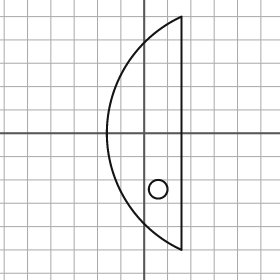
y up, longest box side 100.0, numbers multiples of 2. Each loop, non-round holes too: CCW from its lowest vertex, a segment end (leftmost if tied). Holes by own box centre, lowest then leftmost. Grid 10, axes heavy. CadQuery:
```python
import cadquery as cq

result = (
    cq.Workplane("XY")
    .moveTo(16.0, -50.0)
    .lineTo(16.0, 50.0)
    .threePointArc((-16.0, 0.0), (16.0, -50.0))
    .close()
    .moveTo(6.0, -24.0)
    .circle(4.0)
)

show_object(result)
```